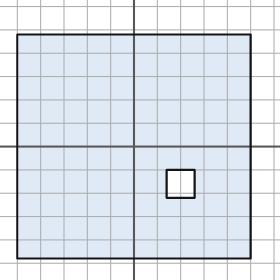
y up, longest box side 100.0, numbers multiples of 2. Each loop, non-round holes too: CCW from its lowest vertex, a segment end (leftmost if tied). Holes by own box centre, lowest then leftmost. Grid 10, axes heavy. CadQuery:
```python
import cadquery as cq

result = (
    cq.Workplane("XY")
    .moveTo(-50.0, -48.0)
    .lineTo(50.0, -48.0)
    .lineTo(50.0, 48.0)
    .lineTo(-50.0, 48.0)
    .close()
    .moveTo(14.0, -22.0)
    .lineTo(26.0, -22.0)
    .lineTo(26.0, -10.0)
    .lineTo(14.0, -10.0)
    .close()
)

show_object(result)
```